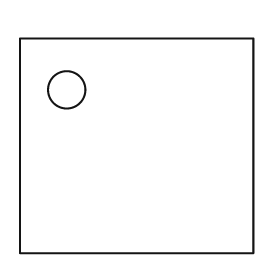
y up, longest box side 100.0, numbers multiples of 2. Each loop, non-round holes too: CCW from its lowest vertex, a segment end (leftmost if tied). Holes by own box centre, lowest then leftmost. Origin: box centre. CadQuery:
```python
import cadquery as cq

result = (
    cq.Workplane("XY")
    .moveTo(-50.0, -46.0)
    .lineTo(50.0, -46.0)
    .lineTo(50.0, 46.0)
    .lineTo(-50.0, 46.0)
    .close()
    .moveTo(-30.0, 24.0)
    .circle(8.0)
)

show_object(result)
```